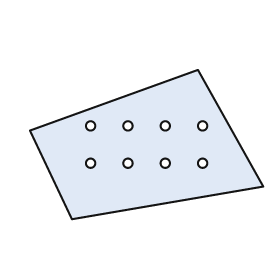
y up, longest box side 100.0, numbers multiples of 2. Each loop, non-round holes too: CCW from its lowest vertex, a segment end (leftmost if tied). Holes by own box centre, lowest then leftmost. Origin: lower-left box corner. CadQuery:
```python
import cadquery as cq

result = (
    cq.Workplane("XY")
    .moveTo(18.0, 0.0)
    .lineTo(100.0, 14.0)
    .lineTo(72.0, 64.0)
    .lineTo(0.0, 38.0)
    .close()
    .moveTo(26.0, 24.0)
    .circle(2.0)
    .moveTo(42.0, 24.0)
    .circle(2.0)
    .moveTo(58.0, 24.0)
    .circle(2.0)
    .moveTo(74.0, 24.0)
    .circle(2.0)
    .moveTo(26.0, 40.0)
    .circle(2.0)
    .moveTo(42.0, 40.0)
    .circle(2.0)
    .moveTo(58.0, 40.0)
    .circle(2.0)
    .moveTo(74.0, 40.0)
    .circle(2.0)
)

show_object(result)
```